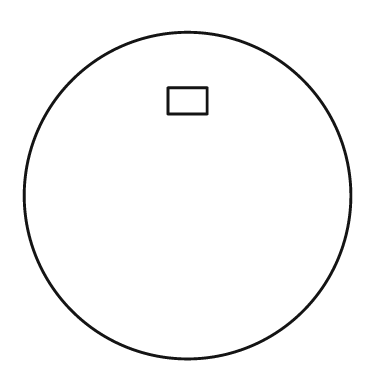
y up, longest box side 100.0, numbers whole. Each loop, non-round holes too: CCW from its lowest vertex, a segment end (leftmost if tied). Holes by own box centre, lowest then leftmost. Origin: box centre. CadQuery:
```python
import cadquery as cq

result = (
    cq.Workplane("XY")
    .moveTo(0.0, 0.0)
    .circle(50.0)
    .moveTo(-6.0, 25.0)
    .lineTo(6.0, 25.0)
    .lineTo(6.0, 33.0)
    .lineTo(-6.0, 33.0)
    .close()
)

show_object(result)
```